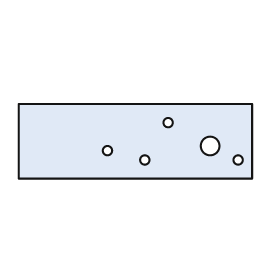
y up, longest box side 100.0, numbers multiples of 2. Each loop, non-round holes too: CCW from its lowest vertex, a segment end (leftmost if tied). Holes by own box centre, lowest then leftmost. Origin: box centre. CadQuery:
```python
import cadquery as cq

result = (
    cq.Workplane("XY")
    .moveTo(-50.0, -16.0)
    .lineTo(50.0, -16.0)
    .lineTo(50.0, 16.0)
    .lineTo(-50.0, 16.0)
    .close()
    .moveTo(4.0, -8.0)
    .circle(2.0)
    .moveTo(44.0, -8.0)
    .circle(2.0)
    .moveTo(-12.0, -4.0)
    .circle(2.0)
    .moveTo(32.0, -2.0)
    .circle(4.0)
    .moveTo(14.0, 8.0)
    .circle(2.0)
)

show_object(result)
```